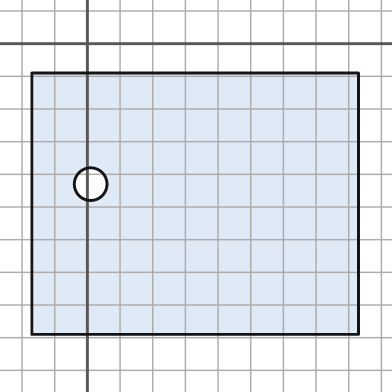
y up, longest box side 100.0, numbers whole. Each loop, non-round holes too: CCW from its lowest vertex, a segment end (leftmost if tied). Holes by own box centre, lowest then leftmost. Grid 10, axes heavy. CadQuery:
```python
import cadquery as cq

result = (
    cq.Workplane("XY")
    .moveTo(-17.0, -89.0)
    .lineTo(83.0, -89.0)
    .lineTo(83.0, -9.0)
    .lineTo(-17.0, -9.0)
    .close()
    .moveTo(1.0, -43.0)
    .circle(5.0)
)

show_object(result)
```